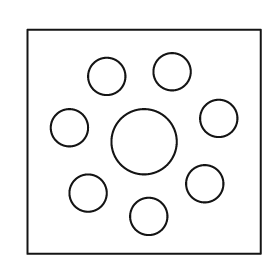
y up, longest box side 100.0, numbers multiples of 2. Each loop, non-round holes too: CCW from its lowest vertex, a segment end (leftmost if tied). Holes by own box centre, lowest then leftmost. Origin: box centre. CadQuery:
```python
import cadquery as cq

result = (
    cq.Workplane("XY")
    .moveTo(-50.0, -48.0)
    .lineTo(50.0, -48.0)
    .lineTo(50.0, 48.0)
    .lineTo(-50.0, 48.0)
    .close()
    .moveTo(2.0, -32.0)
    .circle(8.0)
    .moveTo(-24.0, -22.0)
    .circle(8.0)
    .moveTo(26.0, -18.0)
    .circle(8.0)
    .moveTo(0.0, 0.0)
    .circle(14.0)
    .moveTo(-32.0, 6.0)
    .circle(8.0)
    .moveTo(32.0, 10.0)
    .circle(8.0)
    .moveTo(-16.0, 28.0)
    .circle(8.0)
    .moveTo(12.0, 30.0)
    .circle(8.0)
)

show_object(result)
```